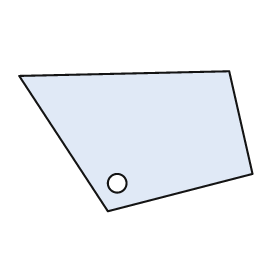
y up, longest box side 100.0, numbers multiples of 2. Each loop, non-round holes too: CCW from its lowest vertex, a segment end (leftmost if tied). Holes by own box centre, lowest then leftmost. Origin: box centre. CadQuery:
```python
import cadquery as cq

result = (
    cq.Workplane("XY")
    .moveTo(-12.0, -30.0)
    .lineTo(50.0, -14.0)
    .lineTo(40.0, 30.0)
    .lineTo(-50.0, 28.0)
    .close()
    .moveTo(-8.0, -18.0)
    .circle(4.0)
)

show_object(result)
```